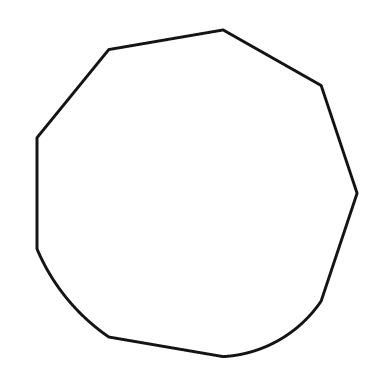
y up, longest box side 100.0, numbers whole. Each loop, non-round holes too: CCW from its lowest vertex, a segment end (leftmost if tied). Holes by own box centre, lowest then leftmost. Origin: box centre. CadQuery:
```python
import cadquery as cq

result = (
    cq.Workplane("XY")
    .moveTo(8.0, -50.0)
    .threePointArc((25.0, -45.0), (38.0, -33.0))
    .lineTo(49.0, 0.0)
    .lineTo(38.0, 33.0)
    .lineTo(8.0, 50.0)
    .lineTo(-27.0, 44.0)
    .lineTo(-49.0, 17.0)
    .lineTo(-49.0, -17.0)
    .threePointArc((-40.0, -32.0), (-27.0, -44.0))
    .close()
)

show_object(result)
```